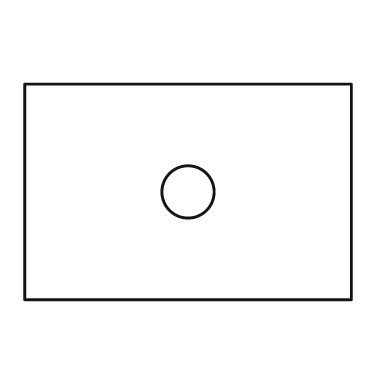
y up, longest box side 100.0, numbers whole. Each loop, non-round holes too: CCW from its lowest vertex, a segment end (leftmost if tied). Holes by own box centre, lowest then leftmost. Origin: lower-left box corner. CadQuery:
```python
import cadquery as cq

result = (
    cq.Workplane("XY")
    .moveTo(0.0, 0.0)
    .lineTo(100.0, 0.0)
    .lineTo(100.0, 66.0)
    .lineTo(0.0, 66.0)
    .close()
    .moveTo(50.0, 33.0)
    .circle(8.0)
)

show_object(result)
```